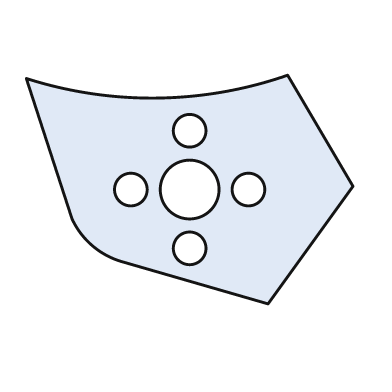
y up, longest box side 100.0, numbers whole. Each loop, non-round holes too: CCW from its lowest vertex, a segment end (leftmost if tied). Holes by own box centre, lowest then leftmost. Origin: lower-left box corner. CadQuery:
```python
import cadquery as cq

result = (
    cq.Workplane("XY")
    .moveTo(74.0, 0.0)
    .lineTo(100.0, 36.0)
    .lineTo(80.0, 70.0)
    .threePointArc((40.0, 63.0), (0.0, 69.0))
    .lineTo(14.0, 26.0)
    .threePointArc((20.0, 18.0), (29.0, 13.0))
    .close()
    .moveTo(50.0, 17.0)
    .circle(5.0)
    .moveTo(32.0, 35.0)
    .circle(5.0)
    .moveTo(50.0, 35.0)
    .circle(9.0)
    .moveTo(68.0, 35.0)
    .circle(5.0)
    .moveTo(50.0, 53.0)
    .circle(5.0)
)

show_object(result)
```